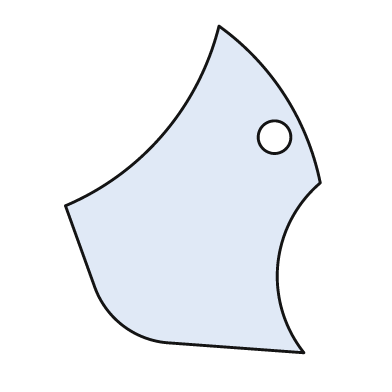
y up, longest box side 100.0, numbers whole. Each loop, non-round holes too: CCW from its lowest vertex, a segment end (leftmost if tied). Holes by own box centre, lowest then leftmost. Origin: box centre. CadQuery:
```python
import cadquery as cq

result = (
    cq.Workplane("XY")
    .moveTo(34.0, -50.0)
    .threePointArc((26.0, -23.0), (39.0, 2.0))
    .threePointArc((28.0, 29.0), (8.0, 50.0))
    .threePointArc((-9.0, 17.0), (-39.0, -5.0))
    .lineTo(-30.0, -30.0)
    .threePointArc((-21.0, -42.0), (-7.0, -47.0))
    .close()
    .moveTo(25.0, 16.0)
    .circle(5.0)
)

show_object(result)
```